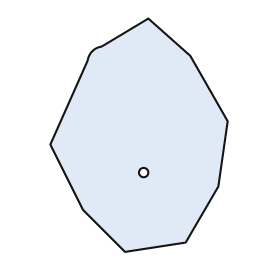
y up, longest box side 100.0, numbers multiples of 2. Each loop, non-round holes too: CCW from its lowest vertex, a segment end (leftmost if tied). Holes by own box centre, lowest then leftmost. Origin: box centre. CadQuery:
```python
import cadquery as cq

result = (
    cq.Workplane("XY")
    .moveTo(-6.0, -50.0)
    .lineTo(20.0, -46.0)
    .lineTo(34.0, -22.0)
    .lineTo(38.0, 6.0)
    .lineTo(22.0, 34.0)
    .lineTo(4.0, 50.0)
    .lineTo(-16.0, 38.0)
    .threePointArc((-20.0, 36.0), (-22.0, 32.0))
    .lineTo(-38.0, -4.0)
    .lineTo(-24.0, -32.0)
    .close()
    .moveTo(2.0, -16.0)
    .circle(2.0)
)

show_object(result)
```